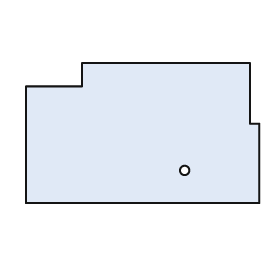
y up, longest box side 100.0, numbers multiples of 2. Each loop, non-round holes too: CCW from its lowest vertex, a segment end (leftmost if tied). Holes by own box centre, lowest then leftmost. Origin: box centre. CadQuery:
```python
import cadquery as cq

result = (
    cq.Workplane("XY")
    .moveTo(-50.0, -30.0)
    .lineTo(50.0, -30.0)
    .lineTo(50.0, 4.0)
    .lineTo(46.0, 4.0)
    .lineTo(46.0, 30.0)
    .lineTo(-26.0, 30.0)
    .lineTo(-26.0, 20.0)
    .lineTo(-50.0, 20.0)
    .close()
    .moveTo(18.0, -16.0)
    .circle(2.0)
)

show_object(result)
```